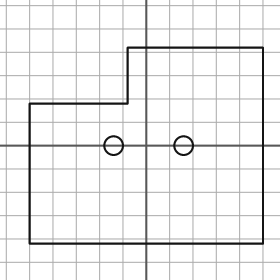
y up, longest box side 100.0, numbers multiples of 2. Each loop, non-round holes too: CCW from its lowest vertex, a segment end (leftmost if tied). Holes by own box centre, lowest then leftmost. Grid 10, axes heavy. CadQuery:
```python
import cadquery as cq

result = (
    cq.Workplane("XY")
    .moveTo(-50.0, -42.0)
    .lineTo(50.0, -42.0)
    .lineTo(50.0, 42.0)
    .lineTo(-8.0, 42.0)
    .lineTo(-8.0, 18.0)
    .lineTo(-50.0, 18.0)
    .close()
    .moveTo(-14.0, 0.0)
    .circle(4.0)
    .moveTo(16.0, 0.0)
    .circle(4.0)
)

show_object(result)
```